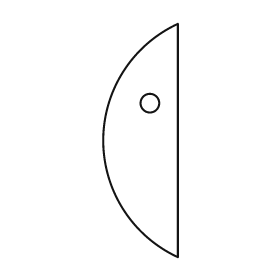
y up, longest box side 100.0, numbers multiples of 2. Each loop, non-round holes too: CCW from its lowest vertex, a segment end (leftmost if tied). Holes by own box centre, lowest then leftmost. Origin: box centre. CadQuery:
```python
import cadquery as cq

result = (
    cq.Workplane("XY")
    .moveTo(16.0, -50.0)
    .lineTo(16.0, 50.0)
    .threePointArc((-16.0, 0.0), (16.0, -50.0))
    .close()
    .moveTo(4.0, 16.0)
    .circle(4.0)
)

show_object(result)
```